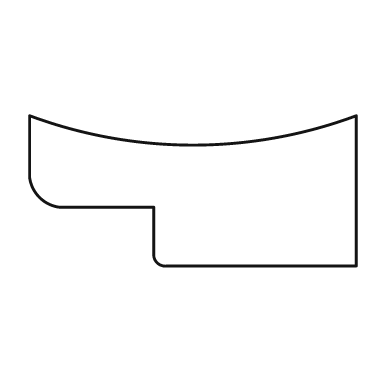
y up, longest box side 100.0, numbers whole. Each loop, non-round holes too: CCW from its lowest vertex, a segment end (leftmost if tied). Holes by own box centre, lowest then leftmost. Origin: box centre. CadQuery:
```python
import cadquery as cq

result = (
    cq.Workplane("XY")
    .moveTo(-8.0, -23.0)
    .lineTo(50.0, -23.0)
    .lineTo(50.0, 23.0)
    .threePointArc((0.0, 14.0), (-50.0, 23.0))
    .lineTo(-50.0, 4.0)
    .threePointArc((-47.0, -2.0), (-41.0, -5.0))
    .lineTo(-12.0, -5.0)
    .lineTo(-12.0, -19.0)
    .threePointArc((-11.0, -22.0), (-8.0, -23.0))
    .close()
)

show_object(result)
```